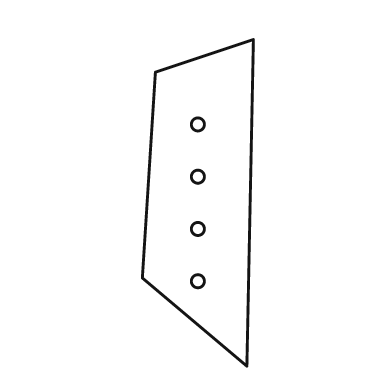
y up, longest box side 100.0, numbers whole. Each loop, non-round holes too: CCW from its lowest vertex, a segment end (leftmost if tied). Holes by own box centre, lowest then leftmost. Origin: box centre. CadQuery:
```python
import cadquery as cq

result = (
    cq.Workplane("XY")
    .moveTo(15.0, -50.0)
    .lineTo(17.0, 50.0)
    .lineTo(-13.0, 40.0)
    .lineTo(-17.0, -23.0)
    .close()
    .moveTo(0.0, -24.0)
    .circle(2.0)
    .moveTo(0.0, -8.0)
    .circle(2.0)
    .moveTo(0.0, 8.0)
    .circle(2.0)
    .moveTo(0.0, 24.0)
    .circle(2.0)
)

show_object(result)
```